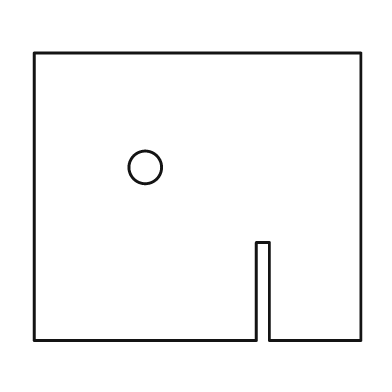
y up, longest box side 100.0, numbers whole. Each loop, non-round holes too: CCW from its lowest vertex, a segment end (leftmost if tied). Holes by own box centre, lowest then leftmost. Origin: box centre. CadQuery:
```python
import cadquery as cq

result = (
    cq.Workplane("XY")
    .moveTo(-50.0, -44.0)
    .lineTo(18.0, -44.0)
    .lineTo(18.0, -14.0)
    .lineTo(22.0, -14.0)
    .lineTo(22.0, -44.0)
    .lineTo(50.0, -44.0)
    .lineTo(50.0, 44.0)
    .lineTo(-50.0, 44.0)
    .close()
    .moveTo(-16.0, 9.0)
    .circle(5.0)
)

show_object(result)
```